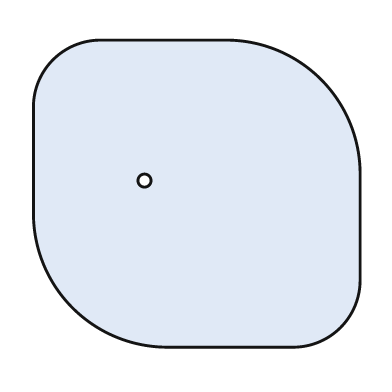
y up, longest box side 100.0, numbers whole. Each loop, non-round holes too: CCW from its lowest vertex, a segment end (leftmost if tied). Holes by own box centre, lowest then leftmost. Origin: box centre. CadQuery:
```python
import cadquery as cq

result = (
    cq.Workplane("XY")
    .moveTo(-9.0, -47.0)
    .lineTo(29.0, -47.0)
    .threePointArc((44.0, -41.0), (50.0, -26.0))
    .lineTo(50.0, 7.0)
    .threePointArc((38.0, 35.0), (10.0, 47.0))
    .lineTo(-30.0, 47.0)
    .threePointArc((-44.0, 41.0), (-50.0, 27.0))
    .lineTo(-50.0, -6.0)
    .threePointArc((-38.0, -35.0), (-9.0, -47.0))
    .close()
    .moveTo(-16.0, 4.0)
    .circle(2.0)
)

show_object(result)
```